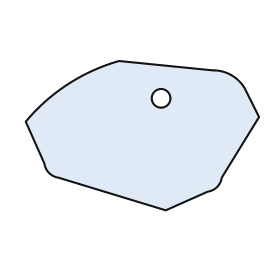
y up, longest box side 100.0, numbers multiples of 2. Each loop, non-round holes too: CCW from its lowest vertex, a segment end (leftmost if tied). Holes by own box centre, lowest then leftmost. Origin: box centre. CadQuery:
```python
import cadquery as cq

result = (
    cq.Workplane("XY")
    .moveTo(10.0, -32.0)
    .lineTo(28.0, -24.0)
    .threePointArc((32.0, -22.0), (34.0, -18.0))
    .lineTo(50.0, 8.0)
    .lineTo(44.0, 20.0)
    .threePointArc((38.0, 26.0), (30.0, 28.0))
    .lineTo(-10.0, 32.0)
    .threePointArc((-32.0, 22.0), (-50.0, 6.0))
    .lineTo(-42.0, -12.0)
    .threePointArc((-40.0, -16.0), (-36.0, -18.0))
    .close()
    .moveTo(8.0, 16.0)
    .circle(4.0)
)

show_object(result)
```